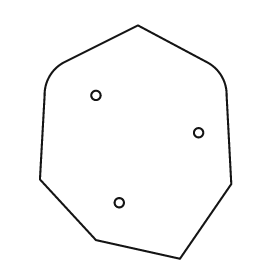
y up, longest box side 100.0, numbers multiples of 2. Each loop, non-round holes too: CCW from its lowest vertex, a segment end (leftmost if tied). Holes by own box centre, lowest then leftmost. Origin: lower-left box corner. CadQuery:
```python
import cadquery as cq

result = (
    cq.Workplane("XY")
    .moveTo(60.0, 0.0)
    .lineTo(82.0, 32.0)
    .lineTo(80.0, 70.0)
    .threePointArc((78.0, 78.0), (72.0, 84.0))
    .lineTo(42.0, 100.0)
    .lineTo(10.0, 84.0)
    .threePointArc((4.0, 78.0), (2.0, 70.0))
    .lineTo(0.0, 34.0)
    .lineTo(24.0, 8.0)
    .close()
    .moveTo(34.0, 24.0)
    .circle(2.0)
    .moveTo(68.0, 54.0)
    .circle(2.0)
    .moveTo(24.0, 70.0)
    .circle(2.0)
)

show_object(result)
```